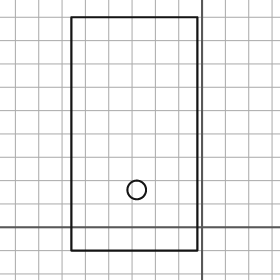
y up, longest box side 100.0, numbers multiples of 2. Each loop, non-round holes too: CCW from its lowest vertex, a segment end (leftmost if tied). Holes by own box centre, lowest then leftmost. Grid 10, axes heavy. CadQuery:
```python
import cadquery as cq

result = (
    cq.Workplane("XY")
    .moveTo(-56.0, -10.0)
    .lineTo(-2.0, -10.0)
    .lineTo(-2.0, 90.0)
    .lineTo(-56.0, 90.0)
    .close()
    .moveTo(-28.0, 16.0)
    .circle(4.0)
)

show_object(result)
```